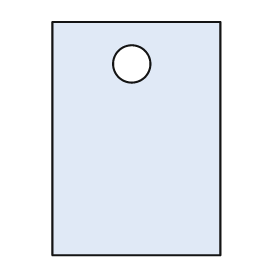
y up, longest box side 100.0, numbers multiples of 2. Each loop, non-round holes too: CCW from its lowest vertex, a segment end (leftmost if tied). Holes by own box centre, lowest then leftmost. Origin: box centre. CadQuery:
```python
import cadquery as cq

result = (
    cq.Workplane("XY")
    .moveTo(-36.0, -50.0)
    .lineTo(36.0, -50.0)
    .lineTo(36.0, 50.0)
    .lineTo(-36.0, 50.0)
    .close()
    .moveTo(-2.0, 32.0)
    .circle(8.0)
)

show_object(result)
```